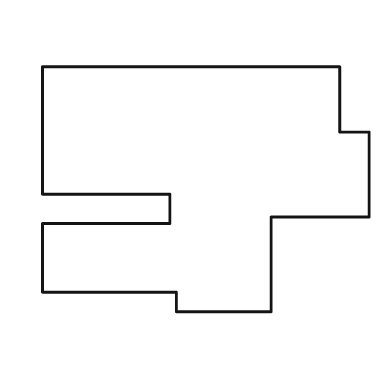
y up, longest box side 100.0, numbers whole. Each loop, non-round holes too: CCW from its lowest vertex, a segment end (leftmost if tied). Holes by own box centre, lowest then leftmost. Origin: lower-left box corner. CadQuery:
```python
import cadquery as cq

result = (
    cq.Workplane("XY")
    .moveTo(41.0, 0.0)
    .lineTo(70.0, 0.0)
    .lineTo(70.0, 29.0)
    .lineTo(100.0, 29.0)
    .lineTo(100.0, 55.0)
    .lineTo(91.0, 55.0)
    .lineTo(91.0, 75.0)
    .lineTo(0.0, 75.0)
    .lineTo(0.0, 36.0)
    .lineTo(39.0, 36.0)
    .lineTo(39.0, 27.0)
    .lineTo(0.0, 27.0)
    .lineTo(0.0, 6.0)
    .lineTo(41.0, 6.0)
    .close()
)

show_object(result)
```